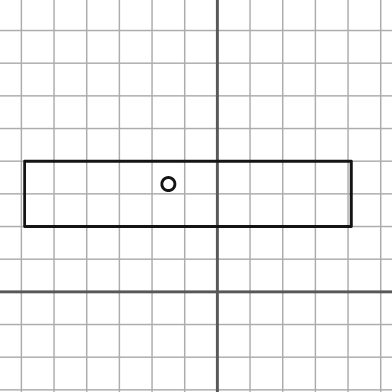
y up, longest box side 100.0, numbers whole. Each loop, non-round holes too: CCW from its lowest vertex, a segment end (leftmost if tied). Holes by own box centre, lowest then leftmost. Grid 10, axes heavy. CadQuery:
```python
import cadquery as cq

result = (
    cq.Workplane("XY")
    .moveTo(-59.0, 20.0)
    .lineTo(41.0, 20.0)
    .lineTo(41.0, 40.0)
    .lineTo(-59.0, 40.0)
    .close()
    .moveTo(-15.0, 33.0)
    .circle(2.0)
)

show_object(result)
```